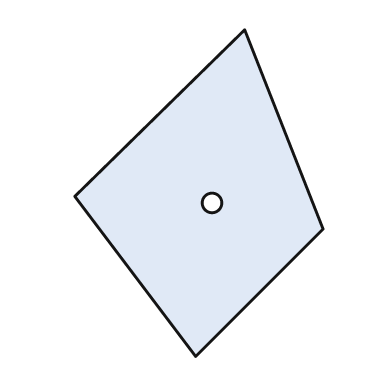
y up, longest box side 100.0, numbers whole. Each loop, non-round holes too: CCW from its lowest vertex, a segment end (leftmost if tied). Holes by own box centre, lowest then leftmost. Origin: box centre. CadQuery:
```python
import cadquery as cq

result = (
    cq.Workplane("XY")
    .moveTo(-1.0, -50.0)
    .lineTo(38.0, -11.0)
    .lineTo(14.0, 50.0)
    .lineTo(-38.0, -1.0)
    .close()
    .moveTo(4.0, -3.0)
    .circle(3.0)
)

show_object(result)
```